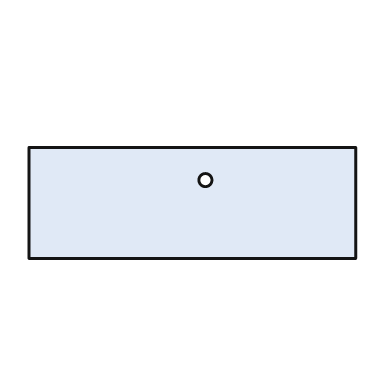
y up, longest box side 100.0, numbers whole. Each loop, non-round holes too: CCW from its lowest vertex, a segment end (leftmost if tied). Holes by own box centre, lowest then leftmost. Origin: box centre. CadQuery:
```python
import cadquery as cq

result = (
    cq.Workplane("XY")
    .moveTo(-50.0, -17.0)
    .lineTo(50.0, -17.0)
    .lineTo(50.0, 17.0)
    .lineTo(-50.0, 17.0)
    .close()
    .moveTo(4.0, 7.0)
    .circle(2.0)
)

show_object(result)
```